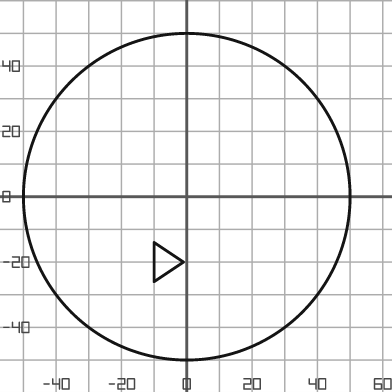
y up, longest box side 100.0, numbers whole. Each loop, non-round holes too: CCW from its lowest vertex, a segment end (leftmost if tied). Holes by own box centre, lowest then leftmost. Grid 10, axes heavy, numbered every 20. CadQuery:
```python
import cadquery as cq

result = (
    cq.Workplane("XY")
    .moveTo(0.0, 0.0)
    .circle(50.0)
    .moveTo(-10.0, -26.0)
    .lineTo(-1.0, -20.0)
    .lineTo(-10.0, -14.0)
    .close()
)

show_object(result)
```